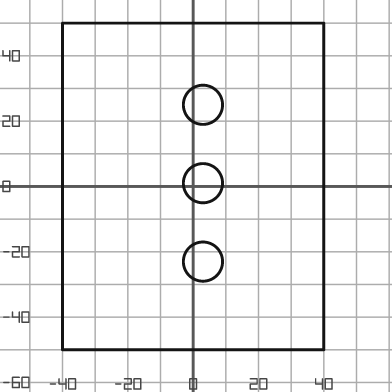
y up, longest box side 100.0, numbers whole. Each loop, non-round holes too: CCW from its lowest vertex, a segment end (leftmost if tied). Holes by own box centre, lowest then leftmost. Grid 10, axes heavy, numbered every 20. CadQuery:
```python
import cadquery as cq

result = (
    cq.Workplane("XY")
    .moveTo(-40.0, -50.0)
    .lineTo(40.0, -50.0)
    .lineTo(40.0, 50.0)
    .lineTo(-40.0, 50.0)
    .close()
    .moveTo(3.0, -23.0)
    .circle(6.0)
    .moveTo(3.0, 1.0)
    .circle(6.0)
    .moveTo(3.0, 25.0)
    .circle(6.0)
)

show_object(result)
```